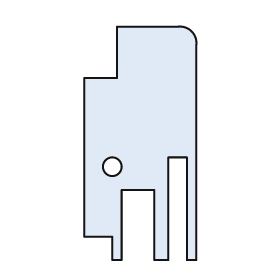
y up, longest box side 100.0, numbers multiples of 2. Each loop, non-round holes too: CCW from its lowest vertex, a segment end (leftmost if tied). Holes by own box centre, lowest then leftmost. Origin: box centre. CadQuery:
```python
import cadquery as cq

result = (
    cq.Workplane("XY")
    .moveTo(-12.0, -50.0)
    .lineTo(-8.0, -50.0)
    .lineTo(-8.0, -20.0)
    .lineTo(6.0, -20.0)
    .lineTo(6.0, -50.0)
    .lineTo(12.0, -50.0)
    .lineTo(12.0, -6.0)
    .lineTo(20.0, -6.0)
    .lineTo(20.0, -50.0)
    .lineTo(24.0, -50.0)
    .lineTo(24.0, 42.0)
    .threePointArc((22.0, 48.0), (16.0, 50.0))
    .lineTo(-10.0, 50.0)
    .lineTo(-10.0, 28.0)
    .lineTo(-24.0, 28.0)
    .lineTo(-24.0, -40.0)
    .lineTo(-12.0, -40.0)
    .close()
    .moveTo(-12.0, -10.0)
    .circle(4.0)
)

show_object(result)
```